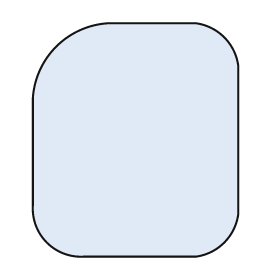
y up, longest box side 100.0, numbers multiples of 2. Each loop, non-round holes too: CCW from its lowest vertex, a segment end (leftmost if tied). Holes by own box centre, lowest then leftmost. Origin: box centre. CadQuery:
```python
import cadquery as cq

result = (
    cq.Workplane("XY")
    .moveTo(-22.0, -50.0)
    .lineTo(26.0, -50.0)
    .threePointArc((38.0, -44.0), (44.0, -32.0))
    .lineTo(44.0, 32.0)
    .threePointArc((38.0, 44.0), (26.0, 50.0))
    .lineTo(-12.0, 50.0)
    .threePointArc((-34.0, 40.0), (-44.0, 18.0))
    .lineTo(-44.0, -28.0)
    .threePointArc((-38.0, -44.0), (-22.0, -50.0))
    .close()
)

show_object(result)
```